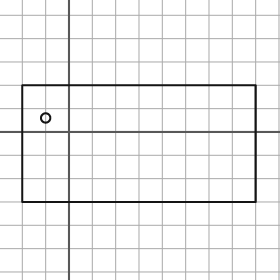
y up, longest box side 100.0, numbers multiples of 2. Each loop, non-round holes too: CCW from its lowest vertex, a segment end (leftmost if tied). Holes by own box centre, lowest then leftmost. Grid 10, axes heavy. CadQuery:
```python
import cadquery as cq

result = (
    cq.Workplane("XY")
    .moveTo(-20.0, -30.0)
    .lineTo(80.0, -30.0)
    .lineTo(80.0, 20.0)
    .lineTo(-20.0, 20.0)
    .close()
    .moveTo(-10.0, 6.0)
    .circle(2.0)
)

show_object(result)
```